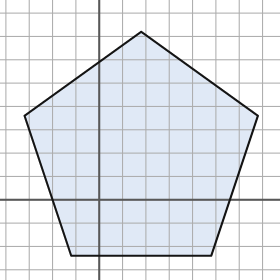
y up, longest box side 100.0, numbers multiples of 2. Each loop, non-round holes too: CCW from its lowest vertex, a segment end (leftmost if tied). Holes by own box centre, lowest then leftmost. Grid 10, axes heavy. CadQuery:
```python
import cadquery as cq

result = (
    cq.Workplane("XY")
    .moveTo(-12.0, -24.0)
    .lineTo(48.0, -24.0)
    .lineTo(68.0, 36.0)
    .lineTo(18.0, 72.0)
    .lineTo(-32.0, 36.0)
    .close()
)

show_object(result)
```